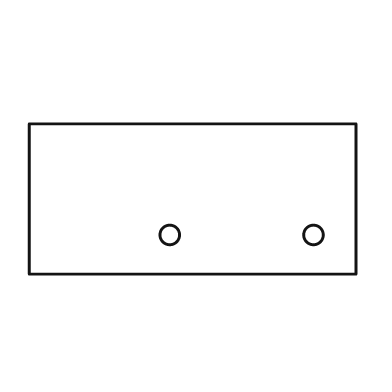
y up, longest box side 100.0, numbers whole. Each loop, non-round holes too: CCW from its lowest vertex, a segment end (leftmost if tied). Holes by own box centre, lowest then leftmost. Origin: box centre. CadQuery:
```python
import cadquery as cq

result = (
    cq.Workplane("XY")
    .moveTo(-50.0, -23.0)
    .lineTo(50.0, -23.0)
    .lineTo(50.0, 23.0)
    .lineTo(-50.0, 23.0)
    .close()
    .moveTo(-7.0, -11.0)
    .circle(3.0)
    .moveTo(37.0, -11.0)
    .circle(3.0)
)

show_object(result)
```